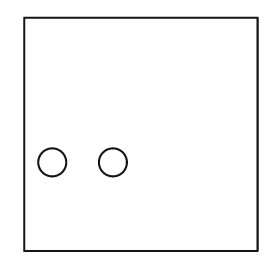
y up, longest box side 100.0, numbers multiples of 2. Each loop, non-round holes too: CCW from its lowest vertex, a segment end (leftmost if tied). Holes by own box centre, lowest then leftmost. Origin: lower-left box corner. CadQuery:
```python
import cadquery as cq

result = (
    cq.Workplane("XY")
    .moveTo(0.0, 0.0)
    .lineTo(100.0, 0.0)
    .lineTo(100.0, 100.0)
    .lineTo(0.0, 100.0)
    .close()
    .moveTo(12.0, 38.0)
    .circle(6.0)
    .moveTo(38.0, 38.0)
    .circle(6.0)
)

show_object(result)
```